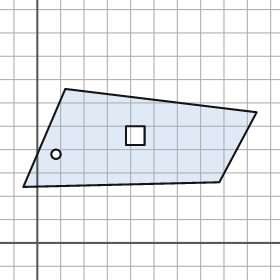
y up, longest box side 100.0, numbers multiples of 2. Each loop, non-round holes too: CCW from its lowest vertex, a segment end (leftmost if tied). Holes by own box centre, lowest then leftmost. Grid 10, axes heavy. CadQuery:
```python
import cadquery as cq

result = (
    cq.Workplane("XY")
    .moveTo(-6.0, 24.0)
    .lineTo(78.0, 26.0)
    .lineTo(94.0, 56.0)
    .lineTo(12.0, 66.0)
    .close()
    .moveTo(8.0, 38.0)
    .circle(2.0)
    .moveTo(38.0, 42.0)
    .lineTo(46.0, 42.0)
    .lineTo(46.0, 50.0)
    .lineTo(38.0, 50.0)
    .close()
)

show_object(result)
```